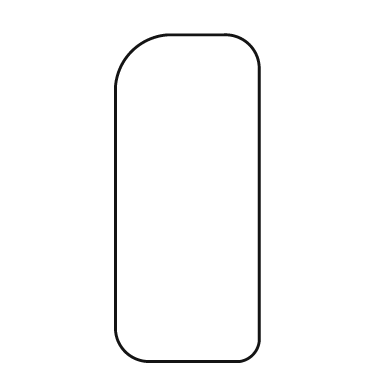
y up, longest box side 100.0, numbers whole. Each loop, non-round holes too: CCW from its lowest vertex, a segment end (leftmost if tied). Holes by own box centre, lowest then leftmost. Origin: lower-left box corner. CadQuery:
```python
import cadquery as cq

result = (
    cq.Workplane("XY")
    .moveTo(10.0, 0.0)
    .lineTo(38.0, 0.0)
    .threePointArc((42.0, 2.0), (44.0, 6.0))
    .lineTo(44.0, 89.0)
    .threePointArc((41.0, 97.0), (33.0, 100.0))
    .lineTo(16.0, 100.0)
    .threePointArc((5.0, 95.0), (0.0, 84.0))
    .lineTo(0.0, 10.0)
    .threePointArc((3.0, 3.0), (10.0, 0.0))
    .close()
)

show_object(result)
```